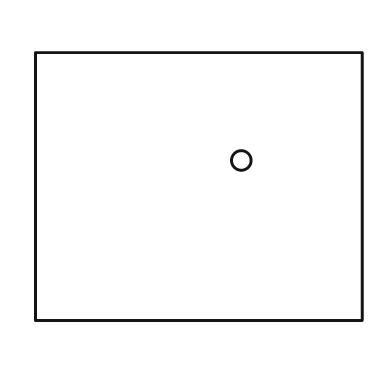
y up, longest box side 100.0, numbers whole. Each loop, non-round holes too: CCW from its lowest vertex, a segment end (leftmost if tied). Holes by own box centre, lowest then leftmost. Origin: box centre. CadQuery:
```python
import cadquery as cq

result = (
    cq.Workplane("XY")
    .moveTo(-50.0, -41.0)
    .lineTo(50.0, -41.0)
    .lineTo(50.0, 41.0)
    .lineTo(-50.0, 41.0)
    .close()
    .moveTo(13.0, 8.0)
    .circle(3.0)
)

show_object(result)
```